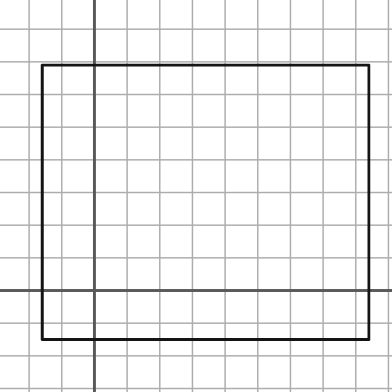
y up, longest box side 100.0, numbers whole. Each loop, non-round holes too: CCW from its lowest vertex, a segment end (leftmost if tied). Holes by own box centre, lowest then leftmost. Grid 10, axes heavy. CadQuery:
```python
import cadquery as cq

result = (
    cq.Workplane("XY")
    .moveTo(-16.0, -15.0)
    .lineTo(84.0, -15.0)
    .lineTo(84.0, 69.0)
    .lineTo(-16.0, 69.0)
    .close()
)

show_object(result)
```